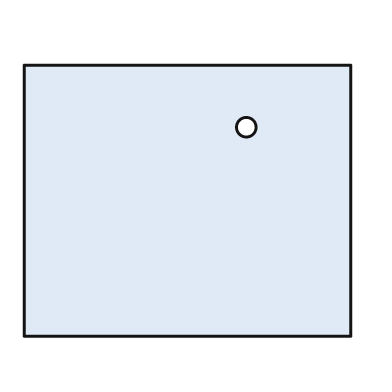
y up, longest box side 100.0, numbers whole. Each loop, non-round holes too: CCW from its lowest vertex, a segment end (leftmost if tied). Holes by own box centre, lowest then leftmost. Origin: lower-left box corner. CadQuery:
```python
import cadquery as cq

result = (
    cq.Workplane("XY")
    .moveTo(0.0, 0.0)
    .lineTo(100.0, 0.0)
    .lineTo(100.0, 83.0)
    .lineTo(0.0, 83.0)
    .close()
    .moveTo(68.0, 64.0)
    .circle(3.0)
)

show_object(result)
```